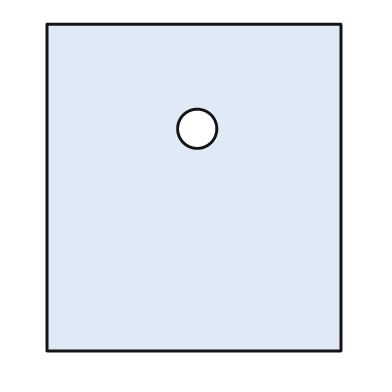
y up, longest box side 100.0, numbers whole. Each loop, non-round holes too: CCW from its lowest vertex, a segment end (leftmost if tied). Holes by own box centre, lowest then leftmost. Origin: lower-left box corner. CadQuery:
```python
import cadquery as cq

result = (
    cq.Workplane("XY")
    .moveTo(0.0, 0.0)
    .lineTo(90.0, 0.0)
    .lineTo(90.0, 100.0)
    .lineTo(0.0, 100.0)
    .close()
    .moveTo(46.0, 68.0)
    .circle(6.0)
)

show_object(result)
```